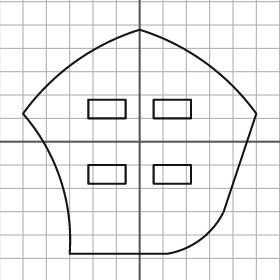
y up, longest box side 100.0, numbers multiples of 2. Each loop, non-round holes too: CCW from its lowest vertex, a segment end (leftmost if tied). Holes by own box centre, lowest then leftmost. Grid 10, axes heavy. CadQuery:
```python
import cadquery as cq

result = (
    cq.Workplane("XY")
    .moveTo(-30.0, -48.0)
    .lineTo(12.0, -48.0)
    .threePointArc((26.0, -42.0), (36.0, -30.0))
    .lineTo(50.0, 12.0)
    .threePointArc((28.0, 34.0), (0.0, 48.0))
    .threePointArc((-28.0, 34.0), (-50.0, 12.0))
    .threePointArc((-34.0, -16.0), (-30.0, -48.0))
    .close()
    .moveTo(-22.0, -18.0)
    .lineTo(-6.0, -18.0)
    .lineTo(-6.0, -10.0)
    .lineTo(-22.0, -10.0)
    .close()
    .moveTo(6.0, -18.0)
    .lineTo(22.0, -18.0)
    .lineTo(22.0, -10.0)
    .lineTo(6.0, -10.0)
    .close()
    .moveTo(-22.0, 10.0)
    .lineTo(-6.0, 10.0)
    .lineTo(-6.0, 18.0)
    .lineTo(-22.0, 18.0)
    .close()
    .moveTo(6.0, 10.0)
    .lineTo(22.0, 10.0)
    .lineTo(22.0, 18.0)
    .lineTo(6.0, 18.0)
    .close()
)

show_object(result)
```